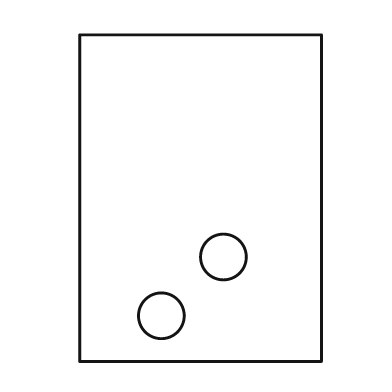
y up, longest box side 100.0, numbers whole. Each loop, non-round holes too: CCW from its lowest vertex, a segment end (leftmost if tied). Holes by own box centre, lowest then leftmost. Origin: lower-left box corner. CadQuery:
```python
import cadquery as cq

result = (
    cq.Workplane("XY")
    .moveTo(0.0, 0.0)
    .lineTo(74.0, 0.0)
    .lineTo(74.0, 100.0)
    .lineTo(0.0, 100.0)
    .close()
    .moveTo(25.0, 14.0)
    .circle(7.0)
    .moveTo(44.0, 32.0)
    .circle(7.0)
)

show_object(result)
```